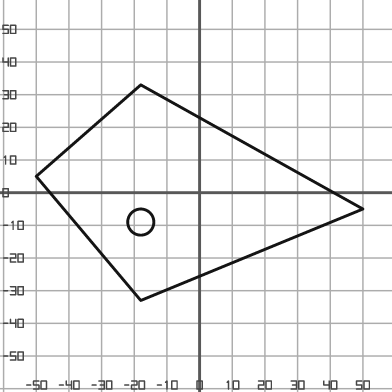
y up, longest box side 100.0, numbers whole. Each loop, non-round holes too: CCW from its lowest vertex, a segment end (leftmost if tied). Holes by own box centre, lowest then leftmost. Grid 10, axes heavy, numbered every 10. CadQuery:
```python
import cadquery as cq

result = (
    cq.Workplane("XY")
    .moveTo(-18.0, -33.0)
    .lineTo(50.0, -5.0)
    .lineTo(-18.0, 33.0)
    .lineTo(-50.0, 5.0)
    .close()
    .moveTo(-18.0, -9.0)
    .circle(4.0)
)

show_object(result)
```